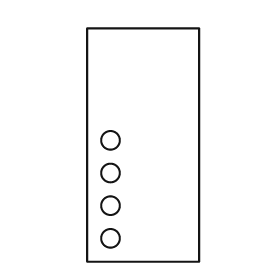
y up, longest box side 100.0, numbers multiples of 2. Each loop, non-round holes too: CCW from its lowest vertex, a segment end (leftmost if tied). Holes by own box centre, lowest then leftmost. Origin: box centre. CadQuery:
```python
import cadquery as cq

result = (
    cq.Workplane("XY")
    .moveTo(-24.0, -50.0)
    .lineTo(24.0, -50.0)
    .lineTo(24.0, 50.0)
    .lineTo(-24.0, 50.0)
    .close()
    .moveTo(-14.0, -40.0)
    .circle(4.0)
    .moveTo(-14.0, -26.0)
    .circle(4.0)
    .moveTo(-14.0, -12.0)
    .circle(4.0)
    .moveTo(-14.0, 2.0)
    .circle(4.0)
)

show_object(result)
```